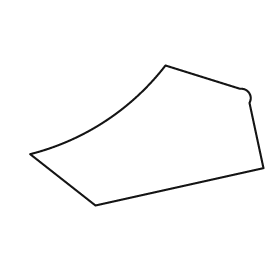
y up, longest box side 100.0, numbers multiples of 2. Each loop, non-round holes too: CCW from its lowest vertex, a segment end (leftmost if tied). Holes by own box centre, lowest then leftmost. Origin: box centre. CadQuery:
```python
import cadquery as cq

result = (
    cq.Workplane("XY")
    .moveTo(-22.0, -30.0)
    .lineTo(50.0, -14.0)
    .lineTo(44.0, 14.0)
    .threePointArc((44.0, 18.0), (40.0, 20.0))
    .lineTo(8.0, 30.0)
    .threePointArc((-18.0, 6.0), (-50.0, -8.0))
    .close()
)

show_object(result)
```